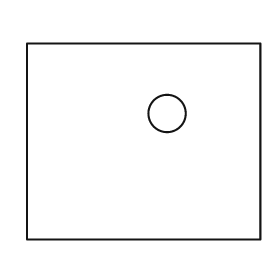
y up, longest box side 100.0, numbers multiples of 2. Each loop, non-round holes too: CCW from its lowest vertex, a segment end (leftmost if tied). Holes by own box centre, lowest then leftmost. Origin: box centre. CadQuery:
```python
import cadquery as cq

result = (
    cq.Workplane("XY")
    .moveTo(-50.0, -42.0)
    .lineTo(50.0, -42.0)
    .lineTo(50.0, 42.0)
    .lineTo(-50.0, 42.0)
    .close()
    .moveTo(10.0, 12.0)
    .circle(8.0)
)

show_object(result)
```